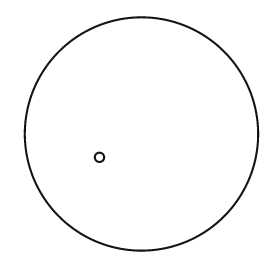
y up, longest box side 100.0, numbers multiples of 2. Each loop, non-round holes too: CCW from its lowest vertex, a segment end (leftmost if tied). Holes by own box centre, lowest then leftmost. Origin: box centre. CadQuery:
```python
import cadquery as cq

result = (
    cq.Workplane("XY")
    .moveTo(0.0, 0.0)
    .circle(50.0)
    .moveTo(-18.0, -10.0)
    .circle(2.0)
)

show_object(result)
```